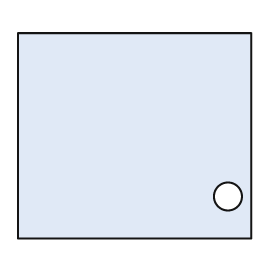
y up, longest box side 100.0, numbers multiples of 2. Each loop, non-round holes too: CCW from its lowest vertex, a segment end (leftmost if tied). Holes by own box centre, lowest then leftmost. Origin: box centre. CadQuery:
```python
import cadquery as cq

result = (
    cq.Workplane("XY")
    .moveTo(-50.0, -44.0)
    .lineTo(50.0, -44.0)
    .lineTo(50.0, 44.0)
    .lineTo(-50.0, 44.0)
    .close()
    .moveTo(40.0, -26.0)
    .circle(6.0)
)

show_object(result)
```